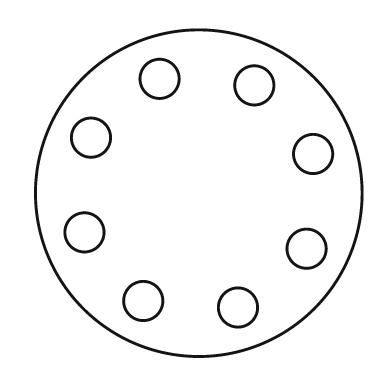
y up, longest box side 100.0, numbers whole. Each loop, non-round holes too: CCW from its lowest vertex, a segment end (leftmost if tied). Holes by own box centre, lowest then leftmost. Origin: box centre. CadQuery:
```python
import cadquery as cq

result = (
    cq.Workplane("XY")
    .moveTo(0.0, 0.0)
    .circle(50.0)
    .moveTo(12.0, -35.0)
    .circle(6.0)
    .moveTo(-17.0, -33.0)
    .circle(6.0)
    .moveTo(33.0, -17.0)
    .circle(6.0)
    .moveTo(-35.0, -12.0)
    .circle(6.0)
    .moveTo(35.0, 12.0)
    .circle(6.0)
    .moveTo(-33.0, 17.0)
    .circle(6.0)
    .moveTo(17.0, 33.0)
    .circle(6.0)
    .moveTo(-12.0, 35.0)
    .circle(6.0)
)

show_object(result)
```